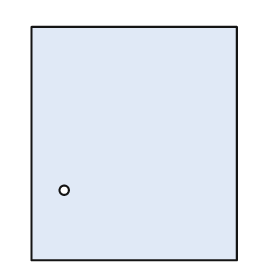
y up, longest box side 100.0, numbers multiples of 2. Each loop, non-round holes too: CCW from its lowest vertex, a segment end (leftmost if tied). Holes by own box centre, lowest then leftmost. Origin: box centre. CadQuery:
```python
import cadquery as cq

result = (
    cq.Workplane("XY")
    .moveTo(-44.0, -50.0)
    .lineTo(44.0, -50.0)
    .lineTo(44.0, 50.0)
    .lineTo(-44.0, 50.0)
    .close()
    .moveTo(-30.0, -20.0)
    .circle(2.0)
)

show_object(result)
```